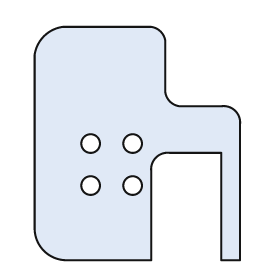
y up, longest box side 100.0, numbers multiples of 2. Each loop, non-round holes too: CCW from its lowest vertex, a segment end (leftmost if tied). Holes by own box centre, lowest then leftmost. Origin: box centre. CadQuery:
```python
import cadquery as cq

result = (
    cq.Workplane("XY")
    .moveTo(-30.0, -50.0)
    .lineTo(6.0, -50.0)
    .lineTo(6.0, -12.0)
    .threePointArc((8.0, -6.0), (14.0, -4.0))
    .lineTo(36.0, -4.0)
    .lineTo(36.0, -50.0)
    .lineTo(44.0, -50.0)
    .lineTo(44.0, 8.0)
    .threePointArc((42.0, 14.0), (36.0, 16.0))
    .lineTo(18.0, 16.0)
    .threePointArc((14.0, 18.0), (12.0, 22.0))
    .lineTo(12.0, 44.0)
    .threePointArc((10.0, 48.0), (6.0, 50.0))
    .lineTo(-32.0, 50.0)
    .threePointArc((-40.0, 46.0), (-44.0, 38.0))
    .lineTo(-44.0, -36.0)
    .threePointArc((-40.0, -46.0), (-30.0, -50.0))
    .close()
    .moveTo(-20.0, -18.0)
    .circle(4.0)
    .moveTo(-2.0, -18.0)
    .circle(4.0)
    .moveTo(-20.0, 0.0)
    .circle(4.0)
    .moveTo(-2.0, 0.0)
    .circle(4.0)
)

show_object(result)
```